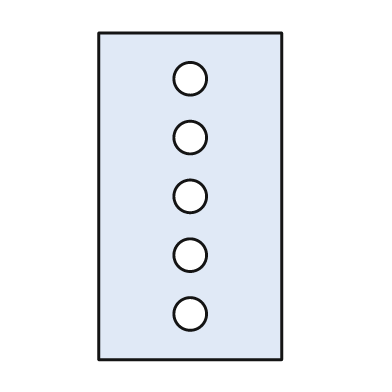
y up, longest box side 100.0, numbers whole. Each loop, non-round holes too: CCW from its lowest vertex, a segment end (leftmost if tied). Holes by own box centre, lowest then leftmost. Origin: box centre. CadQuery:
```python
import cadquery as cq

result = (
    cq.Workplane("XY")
    .moveTo(-28.0, -50.0)
    .lineTo(28.0, -50.0)
    .lineTo(28.0, 50.0)
    .lineTo(-28.0, 50.0)
    .close()
    .moveTo(0.0, -36.0)
    .circle(5.0)
    .moveTo(0.0, -18.0)
    .circle(5.0)
    .moveTo(0.0, 0.0)
    .circle(5.0)
    .moveTo(0.0, 18.0)
    .circle(5.0)
    .moveTo(0.0, 36.0)
    .circle(5.0)
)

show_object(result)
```